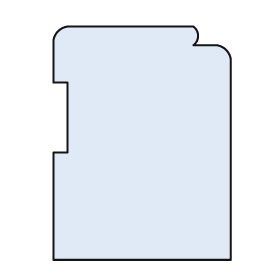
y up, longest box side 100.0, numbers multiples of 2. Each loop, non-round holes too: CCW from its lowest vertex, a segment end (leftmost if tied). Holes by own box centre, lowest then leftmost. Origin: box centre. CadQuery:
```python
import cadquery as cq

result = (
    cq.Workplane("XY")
    .moveTo(-38.0, -50.0)
    .lineTo(38.0, -50.0)
    .lineTo(38.0, 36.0)
    .threePointArc((36.0, 40.0), (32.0, 42.0))
    .lineTo(22.0, 42.0)
    .threePointArc((24.0, 46.0), (22.0, 50.0))
    .lineTo(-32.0, 50.0)
    .threePointArc((-36.0, 48.0), (-38.0, 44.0))
    .lineTo(-38.0, 26.0)
    .lineTo(-32.0, 26.0)
    .lineTo(-32.0, -4.0)
    .lineTo(-38.0, -4.0)
    .close()
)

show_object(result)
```